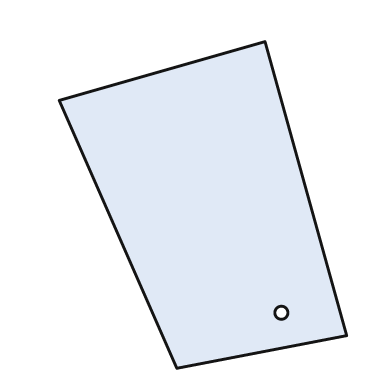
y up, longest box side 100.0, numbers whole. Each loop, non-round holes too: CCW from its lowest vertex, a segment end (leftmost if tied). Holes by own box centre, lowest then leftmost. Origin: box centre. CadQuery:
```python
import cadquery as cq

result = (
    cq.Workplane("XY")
    .moveTo(-8.0, -50.0)
    .lineTo(44.0, -40.0)
    .lineTo(19.0, 50.0)
    .lineTo(-44.0, 32.0)
    .close()
    .moveTo(24.0, -33.0)
    .circle(2.0)
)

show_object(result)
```